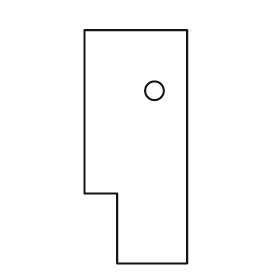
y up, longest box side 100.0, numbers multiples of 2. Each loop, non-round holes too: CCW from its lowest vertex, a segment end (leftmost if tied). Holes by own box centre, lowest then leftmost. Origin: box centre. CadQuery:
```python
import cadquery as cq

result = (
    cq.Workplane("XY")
    .moveTo(-8.0, -50.0)
    .lineTo(22.0, -50.0)
    .lineTo(22.0, 50.0)
    .lineTo(-22.0, 50.0)
    .lineTo(-22.0, -20.0)
    .lineTo(-8.0, -20.0)
    .close()
    .moveTo(8.0, 24.0)
    .circle(4.0)
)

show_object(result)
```